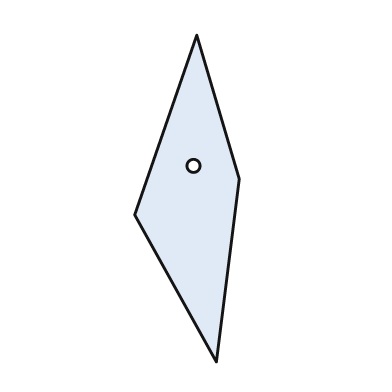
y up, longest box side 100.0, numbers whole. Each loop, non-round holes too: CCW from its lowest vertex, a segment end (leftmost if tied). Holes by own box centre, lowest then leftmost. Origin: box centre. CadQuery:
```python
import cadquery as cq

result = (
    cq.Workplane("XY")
    .moveTo(9.0, -50.0)
    .lineTo(16.0, 6.0)
    .lineTo(3.0, 50.0)
    .lineTo(-16.0, -5.0)
    .close()
    .moveTo(2.0, 10.0)
    .circle(2.0)
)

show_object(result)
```